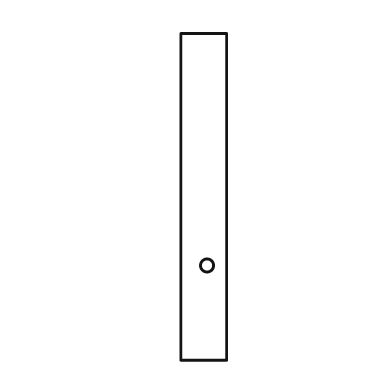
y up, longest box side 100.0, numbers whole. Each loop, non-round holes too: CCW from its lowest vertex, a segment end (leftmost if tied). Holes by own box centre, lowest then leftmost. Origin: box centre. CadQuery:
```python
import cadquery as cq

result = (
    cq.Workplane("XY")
    .moveTo(-7.0, -50.0)
    .lineTo(7.0, -50.0)
    .lineTo(7.0, 50.0)
    .lineTo(-7.0, 50.0)
    .close()
    .moveTo(1.0, -21.0)
    .circle(2.0)
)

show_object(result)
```